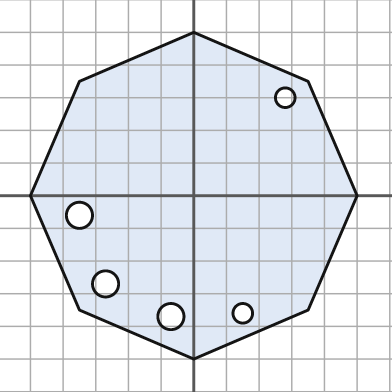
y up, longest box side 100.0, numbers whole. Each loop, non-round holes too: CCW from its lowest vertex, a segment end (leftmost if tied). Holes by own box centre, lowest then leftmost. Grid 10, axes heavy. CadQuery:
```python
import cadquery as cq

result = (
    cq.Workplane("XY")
    .moveTo(0.0, -50.0)
    .lineTo(35.0, -35.0)
    .lineTo(50.0, 0.0)
    .lineTo(35.0, 35.0)
    .lineTo(0.0, 50.0)
    .lineTo(-35.0, 35.0)
    .lineTo(-50.0, 0.0)
    .lineTo(-35.0, -35.0)
    .close()
    .moveTo(-7.0, -37.0)
    .circle(4.0)
    .moveTo(15.0, -36.0)
    .circle(3.0)
    .moveTo(-27.0, -27.0)
    .circle(4.0)
    .moveTo(-35.0, -6.0)
    .circle(4.0)
    .moveTo(28.0, 30.0)
    .circle(3.0)
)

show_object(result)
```